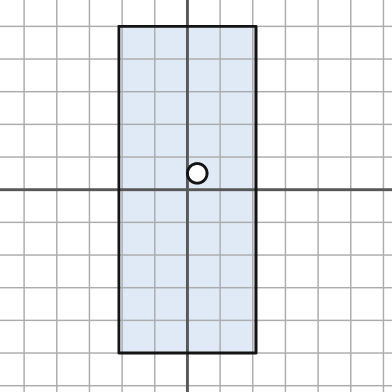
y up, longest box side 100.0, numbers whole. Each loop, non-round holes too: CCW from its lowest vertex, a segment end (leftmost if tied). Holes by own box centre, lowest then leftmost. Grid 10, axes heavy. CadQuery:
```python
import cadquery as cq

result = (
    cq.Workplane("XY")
    .moveTo(-21.0, -50.0)
    .lineTo(21.0, -50.0)
    .lineTo(21.0, 50.0)
    .lineTo(-21.0, 50.0)
    .close()
    .moveTo(3.0, 5.0)
    .circle(3.0)
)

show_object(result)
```